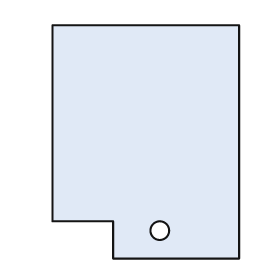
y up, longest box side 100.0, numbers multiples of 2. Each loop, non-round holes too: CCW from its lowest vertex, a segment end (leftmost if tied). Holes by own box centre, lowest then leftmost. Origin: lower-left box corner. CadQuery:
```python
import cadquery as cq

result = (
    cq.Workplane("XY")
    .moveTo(26.0, 0.0)
    .lineTo(80.0, 0.0)
    .lineTo(80.0, 100.0)
    .lineTo(0.0, 100.0)
    .lineTo(0.0, 16.0)
    .lineTo(26.0, 16.0)
    .close()
    .moveTo(46.0, 12.0)
    .circle(4.0)
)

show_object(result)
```